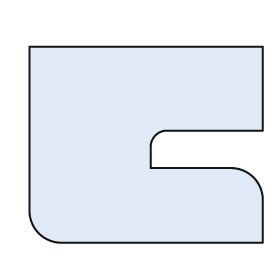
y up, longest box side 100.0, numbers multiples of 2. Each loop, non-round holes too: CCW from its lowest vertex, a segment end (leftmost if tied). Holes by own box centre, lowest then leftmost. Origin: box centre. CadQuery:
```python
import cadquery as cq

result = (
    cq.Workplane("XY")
    .moveTo(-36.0, -42.0)
    .lineTo(50.0, -42.0)
    .lineTo(50.0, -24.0)
    .threePointArc((46.0, -14.0), (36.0, -10.0))
    .lineTo(2.0, -10.0)
    .lineTo(2.0, 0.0)
    .threePointArc((4.0, 4.0), (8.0, 6.0))
    .lineTo(50.0, 6.0)
    .lineTo(50.0, 42.0)
    .lineTo(-50.0, 42.0)
    .lineTo(-50.0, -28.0)
    .threePointArc((-46.0, -38.0), (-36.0, -42.0))
    .close()
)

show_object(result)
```